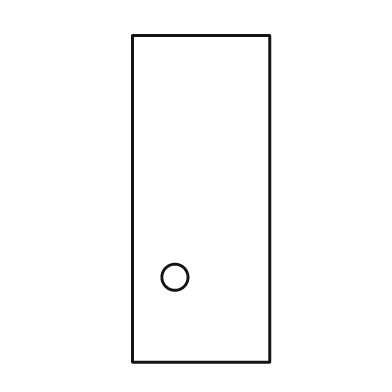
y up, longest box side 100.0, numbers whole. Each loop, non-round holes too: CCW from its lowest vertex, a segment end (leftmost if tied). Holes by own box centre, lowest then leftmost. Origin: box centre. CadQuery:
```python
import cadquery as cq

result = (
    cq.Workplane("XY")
    .moveTo(-21.0, -50.0)
    .lineTo(21.0, -50.0)
    .lineTo(21.0, 50.0)
    .lineTo(-21.0, 50.0)
    .close()
    .moveTo(-8.0, -24.0)
    .circle(4.0)
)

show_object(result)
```